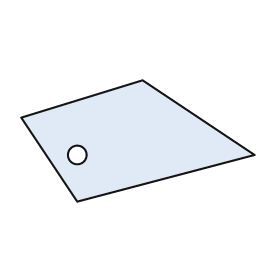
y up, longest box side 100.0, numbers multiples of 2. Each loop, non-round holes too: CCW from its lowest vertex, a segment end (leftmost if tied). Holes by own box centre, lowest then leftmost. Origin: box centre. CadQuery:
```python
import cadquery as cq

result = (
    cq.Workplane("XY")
    .moveTo(-26.0, -26.0)
    .lineTo(50.0, -6.0)
    .lineTo(2.0, 26.0)
    .lineTo(-50.0, 10.0)
    .close()
    .moveTo(-26.0, -6.0)
    .circle(4.0)
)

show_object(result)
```